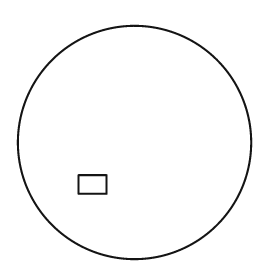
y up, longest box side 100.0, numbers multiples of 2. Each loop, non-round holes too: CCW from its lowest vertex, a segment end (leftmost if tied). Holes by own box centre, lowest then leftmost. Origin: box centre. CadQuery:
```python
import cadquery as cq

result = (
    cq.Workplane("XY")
    .moveTo(0.0, 0.0)
    .circle(50.0)
    .moveTo(-24.0, -22.0)
    .lineTo(-12.0, -22.0)
    .lineTo(-12.0, -14.0)
    .lineTo(-24.0, -14.0)
    .close()
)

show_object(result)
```